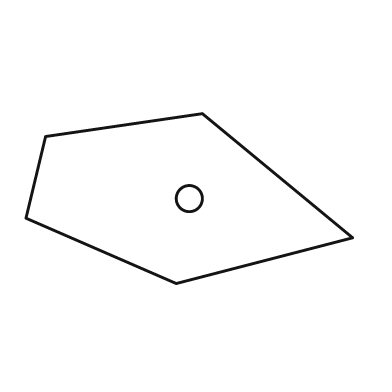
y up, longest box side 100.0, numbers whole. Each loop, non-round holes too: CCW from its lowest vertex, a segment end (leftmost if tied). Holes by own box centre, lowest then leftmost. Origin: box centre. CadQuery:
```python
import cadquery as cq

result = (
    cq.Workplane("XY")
    .moveTo(-4.0, -26.0)
    .lineTo(50.0, -12.0)
    .lineTo(4.0, 26.0)
    .lineTo(-44.0, 19.0)
    .lineTo(-50.0, -6.0)
    .close()
    .moveTo(0.0, 0.0)
    .circle(4.0)
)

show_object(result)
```